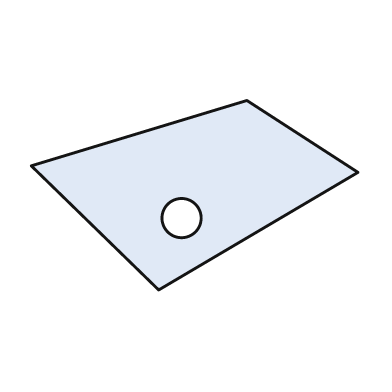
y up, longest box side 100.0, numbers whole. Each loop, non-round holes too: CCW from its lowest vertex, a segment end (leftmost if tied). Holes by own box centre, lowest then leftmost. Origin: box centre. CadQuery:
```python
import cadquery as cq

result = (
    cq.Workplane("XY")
    .moveTo(-11.0, -29.0)
    .lineTo(50.0, 7.0)
    .lineTo(16.0, 29.0)
    .lineTo(-50.0, 9.0)
    .close()
    .moveTo(-4.0, -7.0)
    .circle(6.0)
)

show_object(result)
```